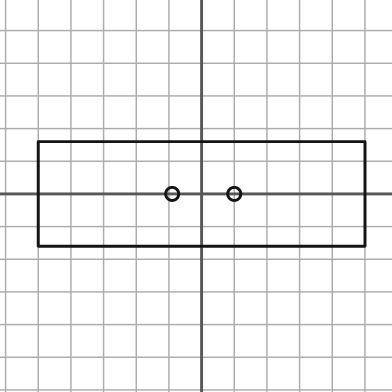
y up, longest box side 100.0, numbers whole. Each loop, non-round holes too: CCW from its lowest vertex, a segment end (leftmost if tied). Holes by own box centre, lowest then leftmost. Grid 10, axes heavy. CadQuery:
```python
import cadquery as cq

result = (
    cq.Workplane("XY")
    .moveTo(-50.0, -16.0)
    .lineTo(50.0, -16.0)
    .lineTo(50.0, 16.0)
    .lineTo(-50.0, 16.0)
    .close()
    .moveTo(-9.0, 0.0)
    .circle(2.0)
    .moveTo(10.0, 0.0)
    .circle(2.0)
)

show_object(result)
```